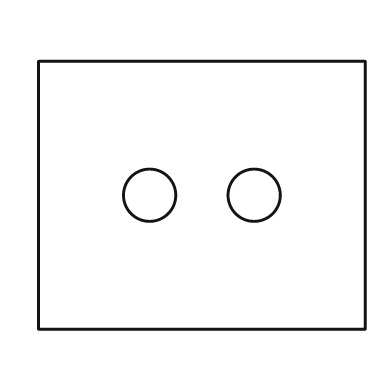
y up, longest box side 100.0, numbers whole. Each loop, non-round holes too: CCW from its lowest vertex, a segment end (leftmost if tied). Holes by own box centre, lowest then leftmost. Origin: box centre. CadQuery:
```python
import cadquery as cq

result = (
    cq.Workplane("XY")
    .moveTo(-50.0, -41.0)
    .lineTo(50.0, -41.0)
    .lineTo(50.0, 41.0)
    .lineTo(-50.0, 41.0)
    .close()
    .moveTo(-16.0, 0.0)
    .circle(8.0)
    .moveTo(16.0, 0.0)
    .circle(8.0)
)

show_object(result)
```